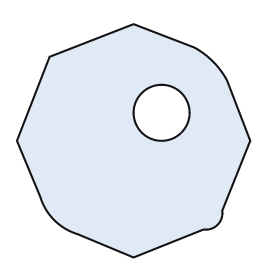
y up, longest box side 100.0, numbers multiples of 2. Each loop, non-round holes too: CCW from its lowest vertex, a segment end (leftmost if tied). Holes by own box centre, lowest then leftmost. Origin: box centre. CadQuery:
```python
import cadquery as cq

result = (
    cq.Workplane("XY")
    .moveTo(0.0, -50.0)
    .lineTo(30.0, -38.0)
    .threePointArc((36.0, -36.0), (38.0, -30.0))
    .lineTo(50.0, 0.0)
    .lineTo(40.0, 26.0)
    .threePointArc((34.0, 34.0), (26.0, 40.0))
    .lineTo(0.0, 50.0)
    .lineTo(-36.0, 36.0)
    .lineTo(-50.0, 0.0)
    .lineTo(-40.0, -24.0)
    .threePointArc((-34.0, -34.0), (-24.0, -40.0))
    .close()
    .moveTo(12.0, 12.0)
    .circle(12.0)
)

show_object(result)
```